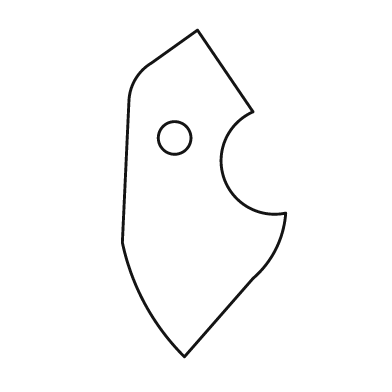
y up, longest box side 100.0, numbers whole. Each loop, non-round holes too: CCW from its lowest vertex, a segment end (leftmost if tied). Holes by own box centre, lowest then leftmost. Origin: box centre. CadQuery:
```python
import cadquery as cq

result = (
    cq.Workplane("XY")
    .moveTo(-6.0, -50.0)
    .lineTo(15.0, -26.0)
    .threePointArc((22.0, -17.0), (25.0, -6.0))
    .threePointArc((6.0, 5.0), (15.0, 25.0))
    .lineTo(-2.0, 50.0)
    .lineTo(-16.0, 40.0)
    .threePointArc((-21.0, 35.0), (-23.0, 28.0))
    .lineTo(-25.0, -15.0)
    .threePointArc((-18.0, -34.0), (-6.0, -50.0))
    .close()
    .moveTo(-9.0, 17.0)
    .circle(5.0)
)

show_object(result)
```